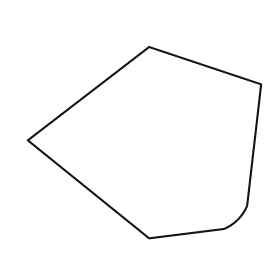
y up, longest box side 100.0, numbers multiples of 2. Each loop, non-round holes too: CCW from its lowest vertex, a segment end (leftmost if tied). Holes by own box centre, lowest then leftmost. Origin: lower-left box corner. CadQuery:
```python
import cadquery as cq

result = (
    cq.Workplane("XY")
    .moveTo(52.0, 0.0)
    .lineTo(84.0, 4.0)
    .threePointArc((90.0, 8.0), (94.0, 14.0))
    .lineTo(100.0, 66.0)
    .lineTo(52.0, 82.0)
    .lineTo(0.0, 42.0)
    .close()
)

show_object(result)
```